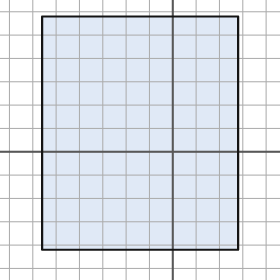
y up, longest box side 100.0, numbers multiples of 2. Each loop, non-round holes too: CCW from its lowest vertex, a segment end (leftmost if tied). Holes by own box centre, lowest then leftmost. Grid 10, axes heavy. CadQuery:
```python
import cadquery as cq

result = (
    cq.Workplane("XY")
    .moveTo(-56.0, -42.0)
    .lineTo(28.0, -42.0)
    .lineTo(28.0, 58.0)
    .lineTo(-56.0, 58.0)
    .close()
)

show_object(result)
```